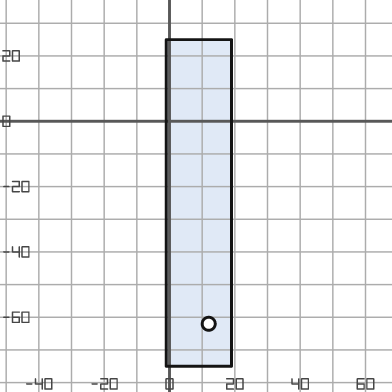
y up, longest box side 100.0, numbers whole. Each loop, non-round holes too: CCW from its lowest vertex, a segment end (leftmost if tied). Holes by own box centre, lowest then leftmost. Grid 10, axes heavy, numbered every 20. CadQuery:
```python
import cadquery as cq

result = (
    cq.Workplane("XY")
    .moveTo(-1.0, -75.0)
    .lineTo(19.0, -75.0)
    .lineTo(19.0, 25.0)
    .lineTo(-1.0, 25.0)
    .close()
    .moveTo(12.0, -62.0)
    .circle(2.0)
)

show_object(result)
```